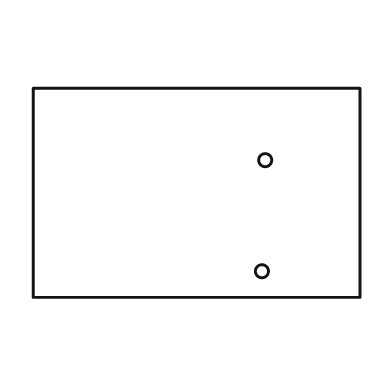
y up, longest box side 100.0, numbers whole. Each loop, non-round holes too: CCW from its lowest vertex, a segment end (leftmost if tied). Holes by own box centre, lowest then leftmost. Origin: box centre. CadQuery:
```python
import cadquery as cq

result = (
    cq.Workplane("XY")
    .moveTo(-50.0, -32.0)
    .lineTo(50.0, -32.0)
    .lineTo(50.0, 32.0)
    .lineTo(-50.0, 32.0)
    .close()
    .moveTo(20.0, -24.0)
    .circle(2.0)
    .moveTo(21.0, 10.0)
    .circle(2.0)
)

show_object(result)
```